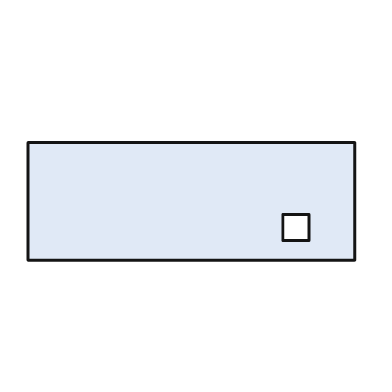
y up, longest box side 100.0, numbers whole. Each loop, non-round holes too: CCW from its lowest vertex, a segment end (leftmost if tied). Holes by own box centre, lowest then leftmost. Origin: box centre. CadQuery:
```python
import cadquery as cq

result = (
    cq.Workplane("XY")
    .moveTo(-50.0, -18.0)
    .lineTo(50.0, -18.0)
    .lineTo(50.0, 18.0)
    .lineTo(-50.0, 18.0)
    .close()
    .moveTo(28.0, -12.0)
    .lineTo(36.0, -12.0)
    .lineTo(36.0, -4.0)
    .lineTo(28.0, -4.0)
    .close()
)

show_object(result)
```